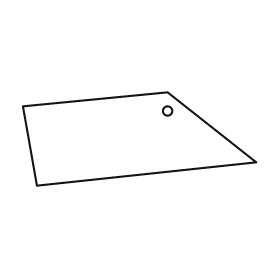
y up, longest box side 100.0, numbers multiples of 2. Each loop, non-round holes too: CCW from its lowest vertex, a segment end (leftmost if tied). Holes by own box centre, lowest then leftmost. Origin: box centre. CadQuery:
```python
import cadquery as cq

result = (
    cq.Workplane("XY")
    .moveTo(-44.0, -20.0)
    .lineTo(50.0, -10.0)
    .lineTo(12.0, 20.0)
    .lineTo(-50.0, 14.0)
    .close()
    .moveTo(12.0, 12.0)
    .circle(2.0)
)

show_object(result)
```